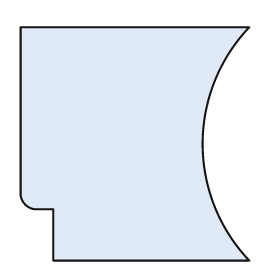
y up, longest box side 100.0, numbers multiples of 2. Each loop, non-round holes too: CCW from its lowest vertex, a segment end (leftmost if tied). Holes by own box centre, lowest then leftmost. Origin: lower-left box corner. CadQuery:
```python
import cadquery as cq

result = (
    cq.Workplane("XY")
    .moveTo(14.0, 0.0)
    .lineTo(98.0, 0.0)
    .threePointArc((78.0, 50.0), (98.0, 100.0))
    .lineTo(0.0, 100.0)
    .lineTo(0.0, 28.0)
    .threePointArc((2.0, 24.0), (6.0, 22.0))
    .lineTo(14.0, 22.0)
    .close()
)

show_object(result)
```